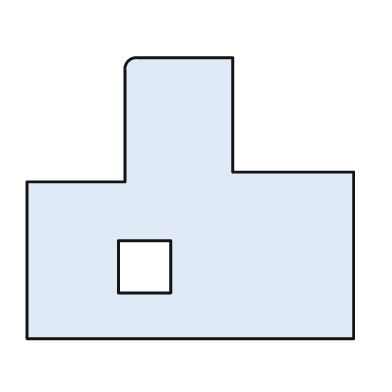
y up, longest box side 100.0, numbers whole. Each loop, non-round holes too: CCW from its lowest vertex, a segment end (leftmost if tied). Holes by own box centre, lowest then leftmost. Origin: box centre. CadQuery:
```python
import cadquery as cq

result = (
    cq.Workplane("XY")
    .moveTo(-50.0, -43.0)
    .lineTo(50.0, -43.0)
    .lineTo(50.0, 8.0)
    .lineTo(13.0, 8.0)
    .lineTo(13.0, 43.0)
    .lineTo(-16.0, 43.0)
    .threePointArc((-19.0, 42.0), (-20.0, 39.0))
    .lineTo(-20.0, 5.0)
    .lineTo(-50.0, 5.0)
    .close()
    .moveTo(-22.0, -29.0)
    .lineTo(-6.0, -29.0)
    .lineTo(-6.0, -13.0)
    .lineTo(-22.0, -13.0)
    .close()
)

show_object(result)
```